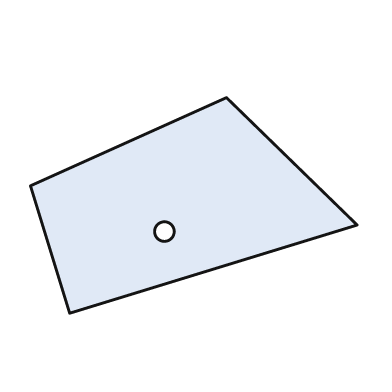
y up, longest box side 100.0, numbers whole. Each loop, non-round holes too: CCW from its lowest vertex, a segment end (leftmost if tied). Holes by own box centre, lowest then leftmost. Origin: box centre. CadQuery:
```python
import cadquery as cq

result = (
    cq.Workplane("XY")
    .moveTo(-38.0, -33.0)
    .lineTo(50.0, -6.0)
    .lineTo(10.0, 33.0)
    .lineTo(-50.0, 6.0)
    .close()
    .moveTo(-9.0, -8.0)
    .circle(3.0)
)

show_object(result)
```